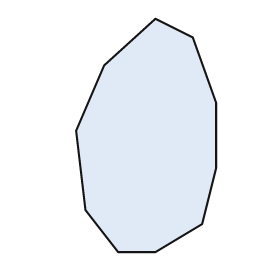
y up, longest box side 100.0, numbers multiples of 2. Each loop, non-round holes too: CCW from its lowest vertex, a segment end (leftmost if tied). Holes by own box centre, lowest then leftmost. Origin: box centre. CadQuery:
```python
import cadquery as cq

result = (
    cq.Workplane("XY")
    .moveTo(-12.0, -50.0)
    .lineTo(4.0, -50.0)
    .lineTo(24.0, -38.0)
    .lineTo(30.0, -14.0)
    .lineTo(30.0, 14.0)
    .lineTo(20.0, 42.0)
    .lineTo(4.0, 50.0)
    .lineTo(-18.0, 30.0)
    .lineTo(-30.0, 2.0)
    .lineTo(-26.0, -32.0)
    .close()
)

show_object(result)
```